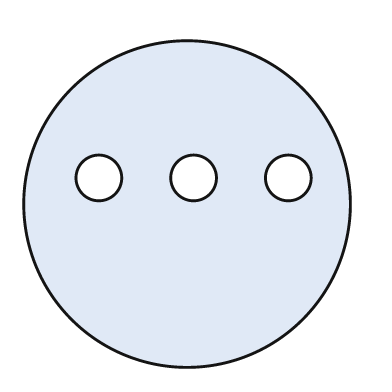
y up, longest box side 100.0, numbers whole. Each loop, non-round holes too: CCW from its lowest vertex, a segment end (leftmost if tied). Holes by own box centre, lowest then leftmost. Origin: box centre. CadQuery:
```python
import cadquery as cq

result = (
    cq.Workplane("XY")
    .moveTo(0.0, 0.0)
    .circle(50.0)
    .moveTo(-27.0, 8.0)
    .circle(7.0)
    .moveTo(2.0, 8.0)
    .circle(7.0)
    .moveTo(31.0, 8.0)
    .circle(7.0)
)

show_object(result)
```